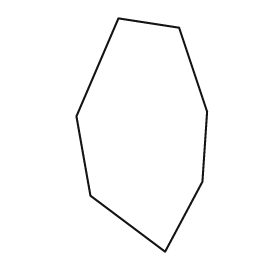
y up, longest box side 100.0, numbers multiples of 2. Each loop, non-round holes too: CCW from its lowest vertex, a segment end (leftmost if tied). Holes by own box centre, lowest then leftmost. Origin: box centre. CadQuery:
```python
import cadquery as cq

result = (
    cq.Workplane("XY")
    .moveTo(10.0, -50.0)
    .lineTo(26.0, -20.0)
    .lineTo(28.0, 10.0)
    .lineTo(16.0, 46.0)
    .lineTo(-10.0, 50.0)
    .lineTo(-28.0, 8.0)
    .lineTo(-22.0, -26.0)
    .close()
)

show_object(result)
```